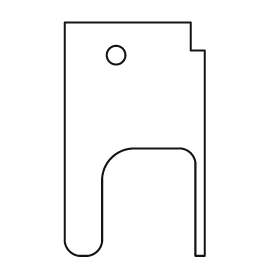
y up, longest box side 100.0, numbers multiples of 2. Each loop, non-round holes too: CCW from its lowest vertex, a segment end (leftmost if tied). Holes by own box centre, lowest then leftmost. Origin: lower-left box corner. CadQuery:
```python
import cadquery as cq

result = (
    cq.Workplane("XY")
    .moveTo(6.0, 0.0)
    .lineTo(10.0, 0.0)
    .threePointArc((14.0, 2.0), (16.0, 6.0))
    .lineTo(16.0, 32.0)
    .threePointArc((20.0, 42.0), (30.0, 46.0))
    .lineTo(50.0, 46.0)
    .threePointArc((54.0, 44.0), (56.0, 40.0))
    .lineTo(56.0, 0.0)
    .lineTo(60.0, 0.0)
    .lineTo(60.0, 88.0)
    .lineTo(54.0, 88.0)
    .lineTo(54.0, 100.0)
    .lineTo(0.0, 100.0)
    .lineTo(0.0, 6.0)
    .threePointArc((2.0, 2.0), (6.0, 0.0))
    .close()
    .moveTo(22.0, 86.0)
    .circle(4.0)
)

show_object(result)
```